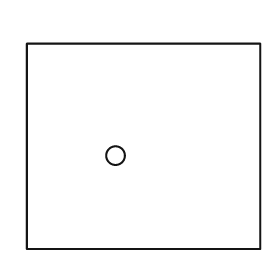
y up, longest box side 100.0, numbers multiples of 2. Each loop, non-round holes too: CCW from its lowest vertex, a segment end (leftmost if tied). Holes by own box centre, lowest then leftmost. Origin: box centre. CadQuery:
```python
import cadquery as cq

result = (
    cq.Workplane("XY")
    .moveTo(-50.0, -44.0)
    .lineTo(50.0, -44.0)
    .lineTo(50.0, 44.0)
    .lineTo(-50.0, 44.0)
    .close()
    .moveTo(-12.0, -4.0)
    .circle(4.0)
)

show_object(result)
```